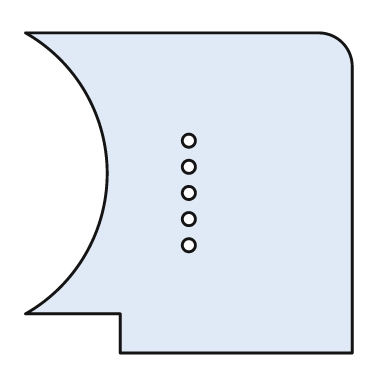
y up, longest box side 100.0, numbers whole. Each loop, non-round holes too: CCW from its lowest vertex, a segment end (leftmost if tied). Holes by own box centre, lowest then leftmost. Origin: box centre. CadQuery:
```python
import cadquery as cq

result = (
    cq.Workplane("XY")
    .moveTo(-21.0, -49.0)
    .lineTo(50.0, -49.0)
    .lineTo(50.0, 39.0)
    .threePointArc((47.0, 46.0), (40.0, 49.0))
    .lineTo(-50.0, 49.0)
    .threePointArc((-25.0, 6.0), (-50.0, -37.0))
    .lineTo(-21.0, -37.0)
    .close()
    .moveTo(0.0, -16.0)
    .circle(2.0)
    .moveTo(0.0, -8.0)
    .circle(2.0)
    .moveTo(0.0, 0.0)
    .circle(2.0)
    .moveTo(0.0, 8.0)
    .circle(2.0)
    .moveTo(0.0, 16.0)
    .circle(2.0)
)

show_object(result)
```